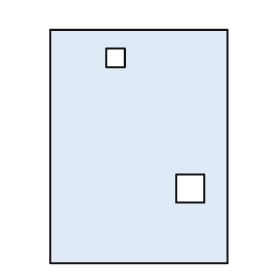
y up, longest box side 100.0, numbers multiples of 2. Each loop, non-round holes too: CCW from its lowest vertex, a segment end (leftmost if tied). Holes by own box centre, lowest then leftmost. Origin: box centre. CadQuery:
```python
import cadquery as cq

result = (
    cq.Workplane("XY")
    .moveTo(-38.0, -50.0)
    .lineTo(38.0, -50.0)
    .lineTo(38.0, 50.0)
    .lineTo(-38.0, 50.0)
    .close()
    .moveTo(16.0, -24.0)
    .lineTo(28.0, -24.0)
    .lineTo(28.0, -12.0)
    .lineTo(16.0, -12.0)
    .close()
    .moveTo(-14.0, 34.0)
    .lineTo(-6.0, 34.0)
    .lineTo(-6.0, 42.0)
    .lineTo(-14.0, 42.0)
    .close()
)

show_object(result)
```